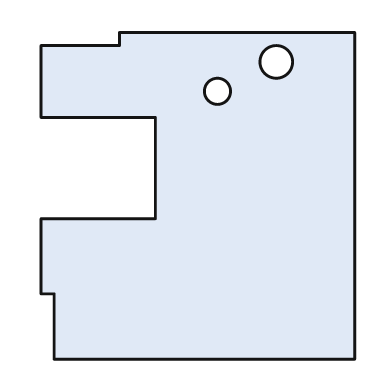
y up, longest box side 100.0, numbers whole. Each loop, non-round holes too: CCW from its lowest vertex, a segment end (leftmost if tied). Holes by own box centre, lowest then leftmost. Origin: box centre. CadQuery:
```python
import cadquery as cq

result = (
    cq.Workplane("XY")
    .moveTo(-44.0, -50.0)
    .lineTo(48.0, -50.0)
    .lineTo(48.0, 50.0)
    .lineTo(-24.0, 50.0)
    .lineTo(-24.0, 46.0)
    .lineTo(-48.0, 46.0)
    .lineTo(-48.0, 24.0)
    .lineTo(-13.0, 24.0)
    .lineTo(-13.0, -7.0)
    .lineTo(-48.0, -7.0)
    .lineTo(-48.0, -30.0)
    .lineTo(-44.0, -30.0)
    .close()
    .moveTo(6.0, 32.0)
    .circle(4.0)
    .moveTo(24.0, 41.0)
    .circle(5.0)
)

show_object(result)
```